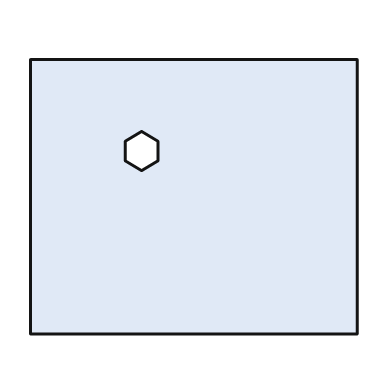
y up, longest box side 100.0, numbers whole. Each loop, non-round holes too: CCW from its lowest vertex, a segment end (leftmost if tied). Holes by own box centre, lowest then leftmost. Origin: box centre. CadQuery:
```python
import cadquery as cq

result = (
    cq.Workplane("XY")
    .moveTo(-50.0, -42.0)
    .lineTo(50.0, -42.0)
    .lineTo(50.0, 42.0)
    .lineTo(-50.0, 42.0)
    .close()
    .moveTo(-16.0, 8.0)
    .lineTo(-11.0, 11.0)
    .lineTo(-11.0, 17.0)
    .lineTo(-16.0, 20.0)
    .lineTo(-21.0, 17.0)
    .lineTo(-21.0, 11.0)
    .close()
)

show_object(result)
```